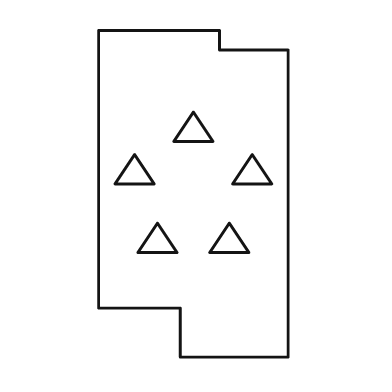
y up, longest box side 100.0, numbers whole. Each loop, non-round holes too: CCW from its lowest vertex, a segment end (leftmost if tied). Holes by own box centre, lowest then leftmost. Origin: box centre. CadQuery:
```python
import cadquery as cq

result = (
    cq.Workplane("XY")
    .moveTo(-4.0, -50.0)
    .lineTo(29.0, -50.0)
    .lineTo(29.0, 44.0)
    .lineTo(8.0, 44.0)
    .lineTo(8.0, 50.0)
    .lineTo(-29.0, 50.0)
    .lineTo(-29.0, -35.0)
    .lineTo(-4.0, -35.0)
    .close()
    .moveTo(-17.0, -18.0)
    .lineTo(-5.0, -18.0)
    .lineTo(-11.0, -9.0)
    .close()
    .moveTo(5.0, -18.0)
    .lineTo(17.0, -18.0)
    .lineTo(11.0, -9.0)
    .close()
    .moveTo(-24.0, 3.0)
    .lineTo(-12.0, 3.0)
    .lineTo(-18.0, 12.0)
    .close()
    .moveTo(12.0, 3.0)
    .lineTo(24.0, 3.0)
    .lineTo(18.0, 12.0)
    .close()
    .moveTo(-6.0, 16.0)
    .lineTo(6.0, 16.0)
    .lineTo(0.0, 25.0)
    .close()
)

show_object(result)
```